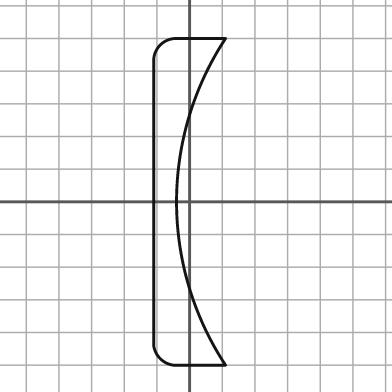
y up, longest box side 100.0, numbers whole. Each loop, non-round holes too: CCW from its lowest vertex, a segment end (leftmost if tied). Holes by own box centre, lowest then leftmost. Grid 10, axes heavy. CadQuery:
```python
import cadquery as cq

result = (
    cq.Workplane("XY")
    .moveTo(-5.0, -50.0)
    .lineTo(11.0, -50.0)
    .threePointArc((-4.0, 0.0), (11.0, 50.0))
    .lineTo(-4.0, 50.0)
    .threePointArc((-9.0, 48.0), (-11.0, 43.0))
    .lineTo(-11.0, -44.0)
    .threePointArc((-9.0, -48.0), (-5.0, -50.0))
    .close()
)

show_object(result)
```